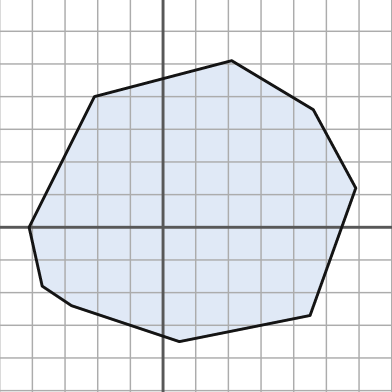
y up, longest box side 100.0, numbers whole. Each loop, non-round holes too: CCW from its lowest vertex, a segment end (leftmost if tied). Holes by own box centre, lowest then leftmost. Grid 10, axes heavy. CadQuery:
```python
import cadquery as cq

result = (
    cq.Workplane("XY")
    .moveTo(5.0, -35.0)
    .lineTo(45.0, -27.0)
    .lineTo(59.0, 12.0)
    .lineTo(46.0, 36.0)
    .lineTo(21.0, 51.0)
    .lineTo(-21.0, 40.0)
    .lineTo(-41.0, 0.0)
    .lineTo(-37.0, -18.0)
    .lineTo(-28.0, -24.0)
    .close()
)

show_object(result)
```